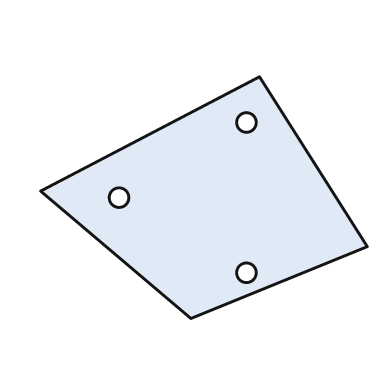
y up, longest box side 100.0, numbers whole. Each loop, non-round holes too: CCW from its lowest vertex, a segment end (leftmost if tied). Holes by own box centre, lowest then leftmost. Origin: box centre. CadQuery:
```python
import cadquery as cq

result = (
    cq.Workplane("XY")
    .moveTo(-4.0, -37.0)
    .lineTo(50.0, -15.0)
    .lineTo(17.0, 37.0)
    .lineTo(-50.0, 2.0)
    .close()
    .moveTo(13.0, -23.0)
    .circle(3.0)
    .moveTo(-26.0, 0.0)
    .circle(3.0)
    .moveTo(13.0, 23.0)
    .circle(3.0)
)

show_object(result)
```